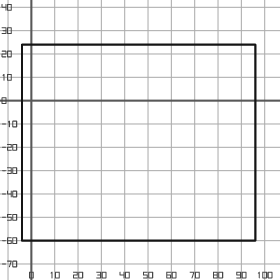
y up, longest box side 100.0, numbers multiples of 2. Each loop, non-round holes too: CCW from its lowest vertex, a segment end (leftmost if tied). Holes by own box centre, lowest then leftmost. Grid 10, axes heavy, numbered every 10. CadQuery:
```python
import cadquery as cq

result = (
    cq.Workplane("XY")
    .moveTo(-4.0, -60.0)
    .lineTo(96.0, -60.0)
    .lineTo(96.0, 24.0)
    .lineTo(-4.0, 24.0)
    .close()
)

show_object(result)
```